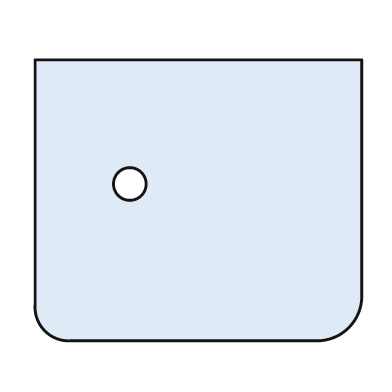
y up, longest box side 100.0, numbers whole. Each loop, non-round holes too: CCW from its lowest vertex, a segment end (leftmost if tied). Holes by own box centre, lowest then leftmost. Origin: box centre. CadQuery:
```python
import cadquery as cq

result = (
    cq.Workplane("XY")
    .moveTo(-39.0, -43.0)
    .lineTo(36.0, -43.0)
    .threePointArc((46.0, -39.0), (50.0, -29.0))
    .lineTo(50.0, 43.0)
    .lineTo(-50.0, 43.0)
    .lineTo(-50.0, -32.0)
    .threePointArc((-47.0, -40.0), (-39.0, -43.0))
    .close()
    .moveTo(-21.0, 5.0)
    .circle(5.0)
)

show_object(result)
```